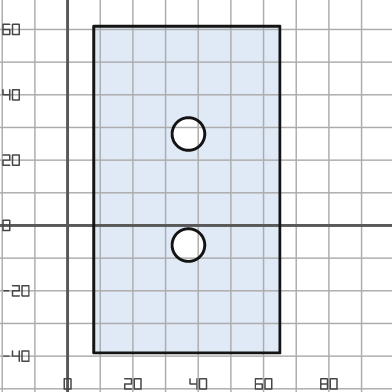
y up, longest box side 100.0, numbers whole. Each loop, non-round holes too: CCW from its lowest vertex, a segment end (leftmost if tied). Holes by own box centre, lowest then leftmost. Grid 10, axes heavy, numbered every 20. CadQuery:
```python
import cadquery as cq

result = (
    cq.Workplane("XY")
    .moveTo(8.0, -39.0)
    .lineTo(65.0, -39.0)
    .lineTo(65.0, 61.0)
    .lineTo(8.0, 61.0)
    .close()
    .moveTo(37.0, -6.0)
    .circle(5.0)
    .moveTo(37.0, 28.0)
    .circle(5.0)
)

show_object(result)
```